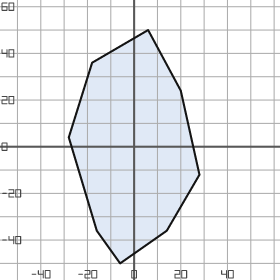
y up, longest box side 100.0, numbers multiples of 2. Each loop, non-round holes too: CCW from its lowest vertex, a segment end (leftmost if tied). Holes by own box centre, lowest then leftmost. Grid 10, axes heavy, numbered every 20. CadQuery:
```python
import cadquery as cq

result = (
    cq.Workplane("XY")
    .moveTo(-6.0, -50.0)
    .lineTo(14.0, -36.0)
    .lineTo(28.0, -12.0)
    .lineTo(20.0, 24.0)
    .lineTo(6.0, 50.0)
    .lineTo(-18.0, 36.0)
    .lineTo(-28.0, 4.0)
    .lineTo(-16.0, -36.0)
    .close()
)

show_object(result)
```